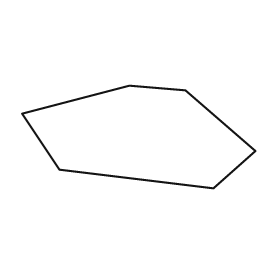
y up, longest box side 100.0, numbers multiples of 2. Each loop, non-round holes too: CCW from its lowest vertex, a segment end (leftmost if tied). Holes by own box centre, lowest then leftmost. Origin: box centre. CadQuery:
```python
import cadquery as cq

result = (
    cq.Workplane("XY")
    .moveTo(32.0, -22.0)
    .lineTo(50.0, -6.0)
    .lineTo(20.0, 20.0)
    .lineTo(-4.0, 22.0)
    .lineTo(-50.0, 10.0)
    .lineTo(-34.0, -14.0)
    .close()
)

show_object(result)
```